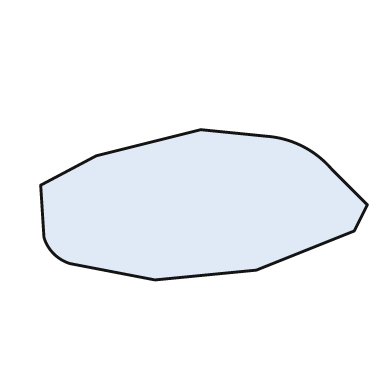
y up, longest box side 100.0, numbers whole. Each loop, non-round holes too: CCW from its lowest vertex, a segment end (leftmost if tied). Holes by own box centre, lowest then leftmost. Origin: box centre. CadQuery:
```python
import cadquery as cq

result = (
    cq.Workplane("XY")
    .moveTo(-15.0, -23.0)
    .lineTo(16.0, -20.0)
    .lineTo(46.0, -8.0)
    .lineTo(50.0, 0.0)
    .lineTo(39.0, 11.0)
    .threePointArc((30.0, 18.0), (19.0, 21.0))
    .lineTo(-1.0, 23.0)
    .lineTo(-33.0, 15.0)
    .lineTo(-50.0, 6.0)
    .lineTo(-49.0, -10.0)
    .threePointArc((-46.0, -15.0), (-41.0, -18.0))
    .close()
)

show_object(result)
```